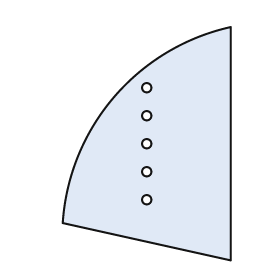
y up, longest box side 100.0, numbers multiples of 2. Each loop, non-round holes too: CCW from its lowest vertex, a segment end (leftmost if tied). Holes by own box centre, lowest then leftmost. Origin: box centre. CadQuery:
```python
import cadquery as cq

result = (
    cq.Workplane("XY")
    .moveTo(36.0, -50.0)
    .lineTo(36.0, 50.0)
    .threePointArc((-14.0, 20.0), (-36.0, -34.0))
    .close()
    .moveTo(0.0, -24.0)
    .circle(2.0)
    .moveTo(0.0, -12.0)
    .circle(2.0)
    .moveTo(0.0, 0.0)
    .circle(2.0)
    .moveTo(0.0, 12.0)
    .circle(2.0)
    .moveTo(0.0, 24.0)
    .circle(2.0)
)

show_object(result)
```